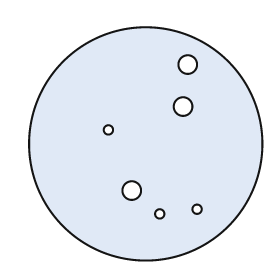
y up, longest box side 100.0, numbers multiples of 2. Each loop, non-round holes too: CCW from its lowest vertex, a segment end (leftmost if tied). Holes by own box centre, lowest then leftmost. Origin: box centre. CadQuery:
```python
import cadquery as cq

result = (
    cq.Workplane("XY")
    .moveTo(0.0, 0.0)
    .circle(50.0)
    .moveTo(6.0, -30.0)
    .circle(2.0)
    .moveTo(22.0, -28.0)
    .circle(2.0)
    .moveTo(-6.0, -20.0)
    .circle(4.0)
    .moveTo(-16.0, 6.0)
    .circle(2.0)
    .moveTo(16.0, 16.0)
    .circle(4.0)
    .moveTo(18.0, 34.0)
    .circle(4.0)
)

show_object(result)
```